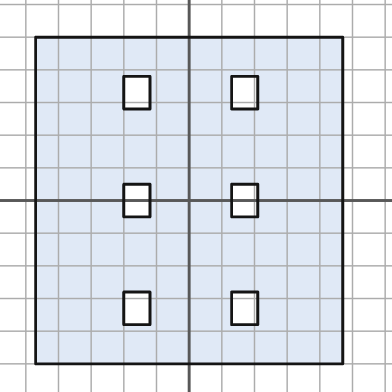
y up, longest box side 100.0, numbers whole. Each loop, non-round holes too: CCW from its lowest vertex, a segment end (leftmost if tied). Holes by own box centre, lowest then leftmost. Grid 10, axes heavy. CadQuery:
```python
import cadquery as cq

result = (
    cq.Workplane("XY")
    .moveTo(-47.0, -50.0)
    .lineTo(47.0, -50.0)
    .lineTo(47.0, 50.0)
    .lineTo(-47.0, 50.0)
    .close()
    .moveTo(-20.0, -38.0)
    .lineTo(-12.0, -38.0)
    .lineTo(-12.0, -28.0)
    .lineTo(-20.0, -28.0)
    .close()
    .moveTo(13.0, -38.0)
    .lineTo(21.0, -38.0)
    .lineTo(21.0, -28.0)
    .lineTo(13.0, -28.0)
    .close()
    .moveTo(-20.0, -5.0)
    .lineTo(-12.0, -5.0)
    .lineTo(-12.0, 5.0)
    .lineTo(-20.0, 5.0)
    .close()
    .moveTo(13.0, -5.0)
    .lineTo(21.0, -5.0)
    .lineTo(21.0, 5.0)
    .lineTo(13.0, 5.0)
    .close()
    .moveTo(-20.0, 28.0)
    .lineTo(-12.0, 28.0)
    .lineTo(-12.0, 38.0)
    .lineTo(-20.0, 38.0)
    .close()
    .moveTo(13.0, 28.0)
    .lineTo(21.0, 28.0)
    .lineTo(21.0, 38.0)
    .lineTo(13.0, 38.0)
    .close()
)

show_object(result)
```